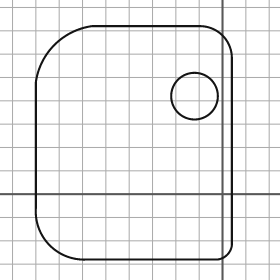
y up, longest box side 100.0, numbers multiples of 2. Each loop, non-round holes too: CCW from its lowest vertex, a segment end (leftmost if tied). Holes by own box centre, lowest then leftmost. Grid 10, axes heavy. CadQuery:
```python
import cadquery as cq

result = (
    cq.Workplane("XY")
    .moveTo(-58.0, -28.0)
    .lineTo(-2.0, -28.0)
    .threePointArc((2.0, -26.0), (4.0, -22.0))
    .lineTo(4.0, 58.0)
    .threePointArc((0.0, 68.0), (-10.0, 72.0))
    .lineTo(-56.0, 72.0)
    .threePointArc((-72.0, 64.0), (-80.0, 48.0))
    .lineTo(-80.0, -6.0)
    .threePointArc((-74.0, -22.0), (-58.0, -28.0))
    .close()
    .moveTo(-12.0, 42.0)
    .circle(10.0)
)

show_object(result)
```